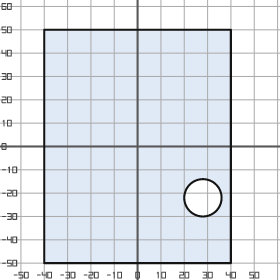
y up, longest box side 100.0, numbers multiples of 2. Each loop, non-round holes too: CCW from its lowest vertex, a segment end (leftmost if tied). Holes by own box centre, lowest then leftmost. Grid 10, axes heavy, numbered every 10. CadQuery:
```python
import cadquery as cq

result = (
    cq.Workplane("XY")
    .moveTo(-40.0, -50.0)
    .lineTo(40.0, -50.0)
    .lineTo(40.0, 50.0)
    .lineTo(-40.0, 50.0)
    .close()
    .moveTo(28.0, -22.0)
    .circle(8.0)
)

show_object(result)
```